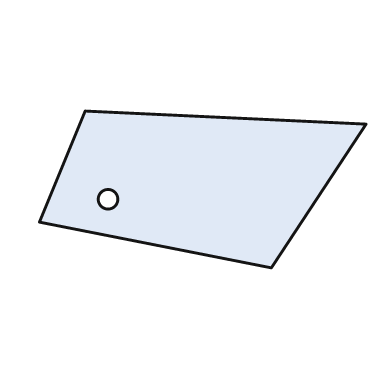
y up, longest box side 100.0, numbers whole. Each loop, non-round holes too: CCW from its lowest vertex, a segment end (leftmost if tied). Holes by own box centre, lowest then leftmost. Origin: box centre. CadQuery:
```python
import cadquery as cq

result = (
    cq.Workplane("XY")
    .moveTo(21.0, -24.0)
    .lineTo(50.0, 20.0)
    .lineTo(-36.0, 24.0)
    .lineTo(-50.0, -10.0)
    .close()
    .moveTo(-29.0, -3.0)
    .circle(3.0)
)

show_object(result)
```